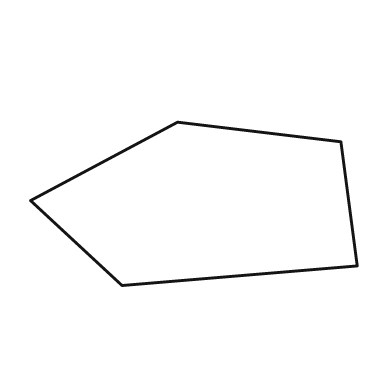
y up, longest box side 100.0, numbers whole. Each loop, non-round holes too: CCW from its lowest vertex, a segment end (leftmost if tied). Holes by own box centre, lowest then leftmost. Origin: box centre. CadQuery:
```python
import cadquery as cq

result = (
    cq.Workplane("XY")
    .moveTo(-22.0, -25.0)
    .lineTo(50.0, -19.0)
    .lineTo(45.0, 19.0)
    .lineTo(-5.0, 25.0)
    .lineTo(-50.0, 1.0)
    .close()
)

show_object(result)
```